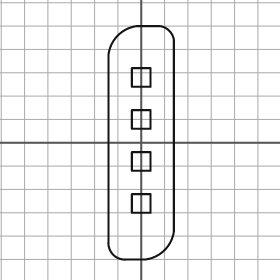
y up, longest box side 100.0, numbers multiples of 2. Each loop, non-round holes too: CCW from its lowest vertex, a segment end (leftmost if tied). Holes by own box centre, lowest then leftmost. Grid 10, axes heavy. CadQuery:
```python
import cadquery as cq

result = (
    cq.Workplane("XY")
    .moveTo(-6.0, -50.0)
    .lineTo(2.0, -50.0)
    .threePointArc((10.0, -46.0), (14.0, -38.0))
    .lineTo(14.0, 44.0)
    .threePointArc((12.0, 48.0), (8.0, 50.0))
    .lineTo(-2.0, 50.0)
    .threePointArc((-10.0, 46.0), (-14.0, 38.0))
    .lineTo(-14.0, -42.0)
    .threePointArc((-12.0, -48.0), (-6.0, -50.0))
    .close()
    .moveTo(-4.0, -30.0)
    .lineTo(4.0, -30.0)
    .lineTo(4.0, -22.0)
    .lineTo(-4.0, -22.0)
    .close()
    .moveTo(-4.0, -12.0)
    .lineTo(4.0, -12.0)
    .lineTo(4.0, -4.0)
    .lineTo(-4.0, -4.0)
    .close()
    .moveTo(-4.0, 6.0)
    .lineTo(4.0, 6.0)
    .lineTo(4.0, 14.0)
    .lineTo(-4.0, 14.0)
    .close()
    .moveTo(-4.0, 24.0)
    .lineTo(4.0, 24.0)
    .lineTo(4.0, 32.0)
    .lineTo(-4.0, 32.0)
    .close()
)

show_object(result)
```